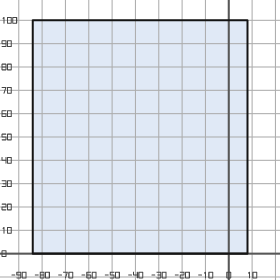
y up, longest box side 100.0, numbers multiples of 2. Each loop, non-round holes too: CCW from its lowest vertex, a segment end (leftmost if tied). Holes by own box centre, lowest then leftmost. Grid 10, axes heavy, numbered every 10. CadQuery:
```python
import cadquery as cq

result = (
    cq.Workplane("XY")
    .moveTo(-84.0, 0.0)
    .lineTo(8.0, 0.0)
    .lineTo(8.0, 100.0)
    .lineTo(-84.0, 100.0)
    .close()
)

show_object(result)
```